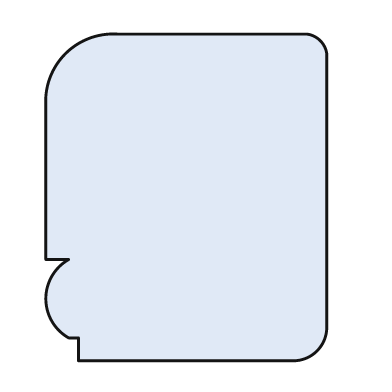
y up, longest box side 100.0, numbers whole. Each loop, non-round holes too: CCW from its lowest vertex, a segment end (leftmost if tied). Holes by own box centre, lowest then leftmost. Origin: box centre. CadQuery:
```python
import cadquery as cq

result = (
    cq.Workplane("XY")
    .moveTo(-33.0, -50.0)
    .lineTo(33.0, -50.0)
    .threePointArc((40.0, -47.0), (43.0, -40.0))
    .lineTo(43.0, 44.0)
    .threePointArc((41.0, 48.0), (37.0, 50.0))
    .lineTo(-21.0, 50.0)
    .threePointArc((-37.0, 44.0), (-43.0, 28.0))
    .lineTo(-43.0, -19.0)
    .lineTo(-36.0, -19.0)
    .threePointArc((-43.0, -31.0), (-36.0, -43.0))
    .lineTo(-33.0, -43.0)
    .close()
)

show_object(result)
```